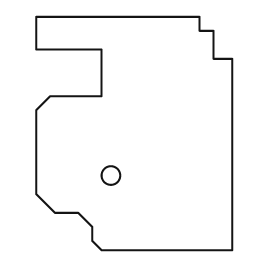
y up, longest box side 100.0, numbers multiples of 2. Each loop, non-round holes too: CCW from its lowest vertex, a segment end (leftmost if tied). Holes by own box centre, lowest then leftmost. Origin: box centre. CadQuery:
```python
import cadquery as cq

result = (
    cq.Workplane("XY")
    .moveTo(-14.0, -50.0)
    .lineTo(42.0, -50.0)
    .lineTo(42.0, 32.0)
    .lineTo(34.0, 32.0)
    .lineTo(34.0, 44.0)
    .lineTo(28.0, 44.0)
    .lineTo(28.0, 50.0)
    .lineTo(-42.0, 50.0)
    .lineTo(-42.0, 36.0)
    .lineTo(-14.0, 36.0)
    .lineTo(-14.0, 16.0)
    .lineTo(-36.0, 16.0)
    .lineTo(-42.0, 10.0)
    .lineTo(-42.0, -26.0)
    .lineTo(-34.0, -34.0)
    .lineTo(-24.0, -34.0)
    .lineTo(-18.0, -40.0)
    .lineTo(-18.0, -46.0)
    .close()
    .moveTo(-10.0, -18.0)
    .circle(4.0)
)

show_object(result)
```